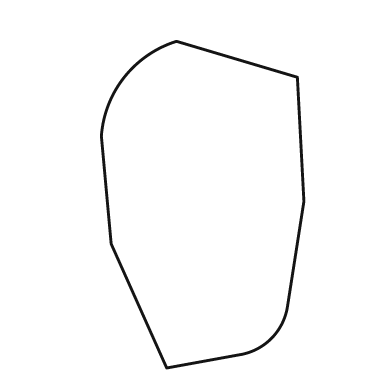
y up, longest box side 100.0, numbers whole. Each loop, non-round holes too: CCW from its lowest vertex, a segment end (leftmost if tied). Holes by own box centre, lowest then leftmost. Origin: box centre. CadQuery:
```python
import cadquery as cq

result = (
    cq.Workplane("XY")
    .moveTo(-11.0, -50.0)
    .lineTo(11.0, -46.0)
    .threePointArc((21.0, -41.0), (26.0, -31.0))
    .lineTo(31.0, 1.0)
    .lineTo(29.0, 39.0)
    .lineTo(-8.0, 50.0)
    .threePointArc((-24.0, 39.0), (-31.0, 21.0))
    .lineTo(-28.0, -12.0)
    .close()
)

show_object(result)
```